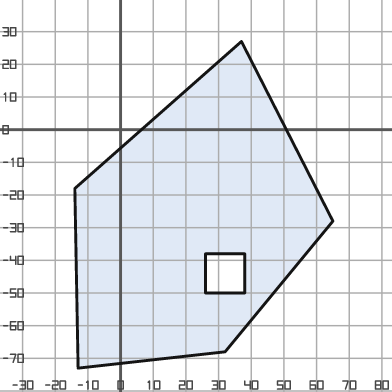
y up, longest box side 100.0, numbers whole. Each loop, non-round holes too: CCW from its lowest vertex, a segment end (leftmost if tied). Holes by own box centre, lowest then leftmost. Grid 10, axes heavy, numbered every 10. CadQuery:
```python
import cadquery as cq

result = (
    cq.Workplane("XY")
    .moveTo(-13.0, -73.0)
    .lineTo(32.0, -68.0)
    .lineTo(65.0, -28.0)
    .lineTo(37.0, 27.0)
    .lineTo(-14.0, -18.0)
    .close()
    .moveTo(26.0, -50.0)
    .lineTo(38.0, -50.0)
    .lineTo(38.0, -38.0)
    .lineTo(26.0, -38.0)
    .close()
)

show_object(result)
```